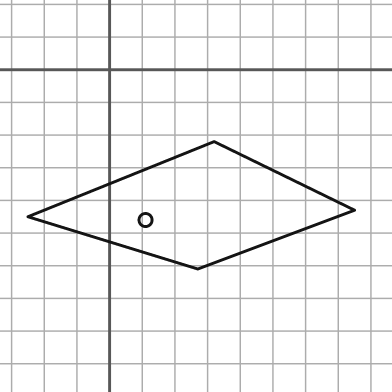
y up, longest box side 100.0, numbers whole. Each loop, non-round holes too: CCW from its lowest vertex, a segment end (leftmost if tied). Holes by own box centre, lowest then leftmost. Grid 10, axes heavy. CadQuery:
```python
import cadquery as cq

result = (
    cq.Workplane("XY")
    .moveTo(27.0, -61.0)
    .lineTo(75.0, -43.0)
    .lineTo(32.0, -22.0)
    .lineTo(-25.0, -45.0)
    .close()
    .moveTo(11.0, -46.0)
    .circle(2.0)
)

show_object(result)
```